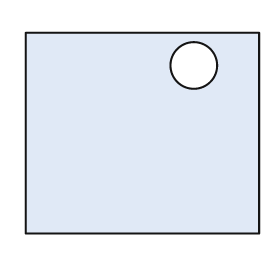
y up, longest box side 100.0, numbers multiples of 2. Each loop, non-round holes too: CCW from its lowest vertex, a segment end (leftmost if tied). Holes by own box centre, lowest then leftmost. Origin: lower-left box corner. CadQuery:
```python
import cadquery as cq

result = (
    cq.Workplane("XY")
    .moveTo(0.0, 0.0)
    .lineTo(100.0, 0.0)
    .lineTo(100.0, 86.0)
    .lineTo(0.0, 86.0)
    .close()
    .moveTo(72.0, 72.0)
    .circle(10.0)
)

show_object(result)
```